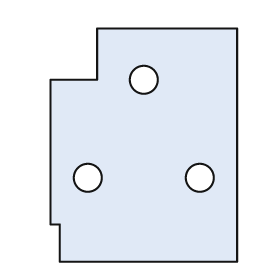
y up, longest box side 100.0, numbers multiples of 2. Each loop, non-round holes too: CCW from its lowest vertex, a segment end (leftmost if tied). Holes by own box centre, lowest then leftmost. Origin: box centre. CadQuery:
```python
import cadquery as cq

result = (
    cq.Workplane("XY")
    .moveTo(-36.0, -50.0)
    .lineTo(40.0, -50.0)
    .lineTo(40.0, 50.0)
    .lineTo(-20.0, 50.0)
    .lineTo(-20.0, 28.0)
    .lineTo(-40.0, 28.0)
    .lineTo(-40.0, -34.0)
    .lineTo(-36.0, -34.0)
    .close()
    .moveTo(-24.0, -14.0)
    .circle(6.0)
    .moveTo(24.0, -14.0)
    .circle(6.0)
    .moveTo(0.0, 28.0)
    .circle(6.0)
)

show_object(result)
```